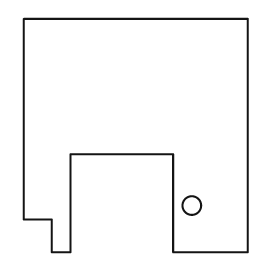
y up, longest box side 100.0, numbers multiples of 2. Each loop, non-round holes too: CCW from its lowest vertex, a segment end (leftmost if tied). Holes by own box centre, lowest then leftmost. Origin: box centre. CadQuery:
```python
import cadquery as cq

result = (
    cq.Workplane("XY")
    .moveTo(-36.0, -50.0)
    .lineTo(-28.0, -50.0)
    .lineTo(-28.0, -8.0)
    .lineTo(16.0, -8.0)
    .lineTo(16.0, -50.0)
    .lineTo(48.0, -50.0)
    .lineTo(48.0, 50.0)
    .lineTo(-48.0, 50.0)
    .lineTo(-48.0, -36.0)
    .lineTo(-36.0, -36.0)
    .close()
    .moveTo(24.0, -30.0)
    .circle(4.0)
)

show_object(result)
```